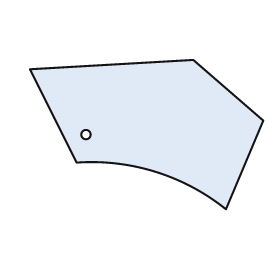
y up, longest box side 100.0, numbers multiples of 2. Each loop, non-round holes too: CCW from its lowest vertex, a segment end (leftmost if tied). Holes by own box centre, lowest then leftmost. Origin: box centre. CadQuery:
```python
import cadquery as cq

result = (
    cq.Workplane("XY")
    .moveTo(34.0, -32.0)
    .lineTo(50.0, 6.0)
    .lineTo(20.0, 32.0)
    .lineTo(-50.0, 28.0)
    .lineTo(-30.0, -12.0)
    .threePointArc((4.0, -16.0), (34.0, -32.0))
    .close()
    .moveTo(-26.0, 0.0)
    .circle(2.0)
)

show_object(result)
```